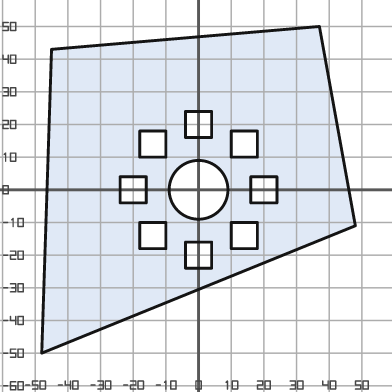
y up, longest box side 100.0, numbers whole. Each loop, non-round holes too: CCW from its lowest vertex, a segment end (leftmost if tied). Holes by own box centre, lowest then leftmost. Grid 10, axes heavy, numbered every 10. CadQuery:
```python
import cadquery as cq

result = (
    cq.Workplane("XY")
    .moveTo(-48.0, -50.0)
    .lineTo(48.0, -11.0)
    .lineTo(37.0, 50.0)
    .lineTo(-45.0, 43.0)
    .close()
    .moveTo(-4.0, -24.0)
    .lineTo(4.0, -24.0)
    .lineTo(4.0, -16.0)
    .lineTo(-4.0, -16.0)
    .close()
    .moveTo(-18.0, -18.0)
    .lineTo(-10.0, -18.0)
    .lineTo(-10.0, -10.0)
    .lineTo(-18.0, -10.0)
    .close()
    .moveTo(10.0, -18.0)
    .lineTo(18.0, -18.0)
    .lineTo(18.0, -10.0)
    .lineTo(10.0, -10.0)
    .close()
    .moveTo(-24.0, -4.0)
    .lineTo(-16.0, -4.0)
    .lineTo(-16.0, 4.0)
    .lineTo(-24.0, 4.0)
    .close()
    .moveTo(0.0, 0.0)
    .circle(9.0)
    .moveTo(16.0, -4.0)
    .lineTo(24.0, -4.0)
    .lineTo(24.0, 4.0)
    .lineTo(16.0, 4.0)
    .close()
    .moveTo(-18.0, 10.0)
    .lineTo(-10.0, 10.0)
    .lineTo(-10.0, 18.0)
    .lineTo(-18.0, 18.0)
    .close()
    .moveTo(10.0, 10.0)
    .lineTo(18.0, 10.0)
    .lineTo(18.0, 18.0)
    .lineTo(10.0, 18.0)
    .close()
    .moveTo(-4.0, 16.0)
    .lineTo(4.0, 16.0)
    .lineTo(4.0, 24.0)
    .lineTo(-4.0, 24.0)
    .close()
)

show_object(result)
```